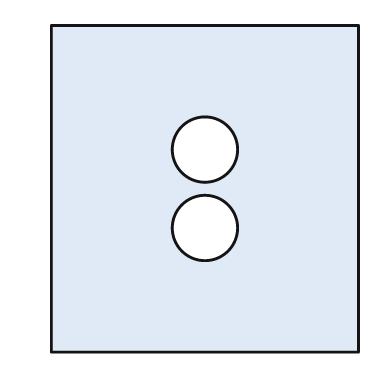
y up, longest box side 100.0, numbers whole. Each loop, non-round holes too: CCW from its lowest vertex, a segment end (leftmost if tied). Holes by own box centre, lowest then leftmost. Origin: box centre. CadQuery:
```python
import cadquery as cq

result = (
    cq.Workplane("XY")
    .moveTo(-47.0, -50.0)
    .lineTo(47.0, -50.0)
    .lineTo(47.0, 50.0)
    .lineTo(-47.0, 50.0)
    .close()
    .moveTo(0.0, -12.0)
    .circle(10.0)
    .moveTo(0.0, 12.0)
    .circle(10.0)
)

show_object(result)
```